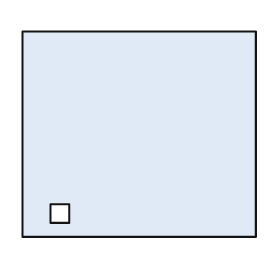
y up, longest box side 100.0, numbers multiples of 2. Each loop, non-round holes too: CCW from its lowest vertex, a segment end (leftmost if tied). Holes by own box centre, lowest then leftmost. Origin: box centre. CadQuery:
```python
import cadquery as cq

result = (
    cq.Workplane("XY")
    .moveTo(-50.0, -44.0)
    .lineTo(50.0, -44.0)
    .lineTo(50.0, 44.0)
    .lineTo(-50.0, 44.0)
    .close()
    .moveTo(-38.0, -38.0)
    .lineTo(-30.0, -38.0)
    .lineTo(-30.0, -30.0)
    .lineTo(-38.0, -30.0)
    .close()
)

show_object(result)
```